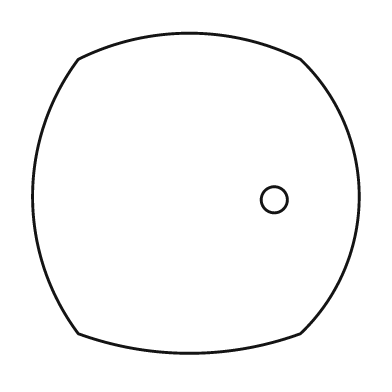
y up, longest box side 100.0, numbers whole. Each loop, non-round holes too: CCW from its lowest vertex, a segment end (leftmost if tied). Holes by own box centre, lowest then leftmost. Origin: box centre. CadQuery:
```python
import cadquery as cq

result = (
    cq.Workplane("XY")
    .moveTo(-36.0, -43.0)
    .threePointArc((-2.0, -49.0), (32.0, -43.0))
    .threePointArc((50.0, -1.0), (32.0, 41.0))
    .threePointArc((-2.0, 49.0), (-36.0, 41.0))
    .threePointArc((-50.0, -1.0), (-36.0, -43.0))
    .close()
    .moveTo(24.0, -2.0)
    .circle(4.0)
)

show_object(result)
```